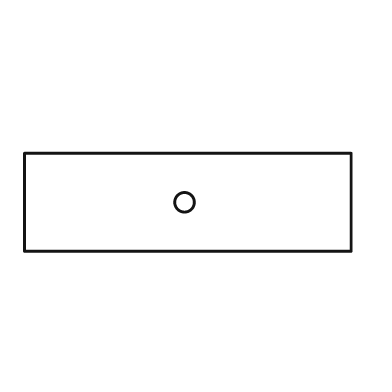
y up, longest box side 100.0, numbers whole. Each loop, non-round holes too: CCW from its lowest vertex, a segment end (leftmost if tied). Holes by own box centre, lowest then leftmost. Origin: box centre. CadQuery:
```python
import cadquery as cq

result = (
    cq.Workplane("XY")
    .moveTo(-50.0, -15.0)
    .lineTo(50.0, -15.0)
    .lineTo(50.0, 15.0)
    .lineTo(-50.0, 15.0)
    .close()
    .moveTo(-1.0, 0.0)
    .circle(3.0)
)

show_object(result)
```